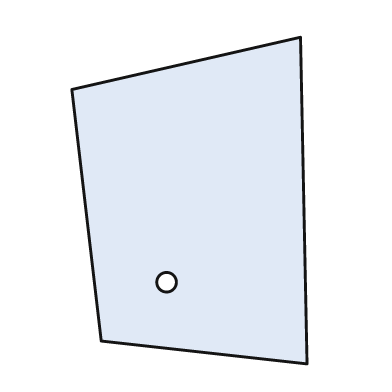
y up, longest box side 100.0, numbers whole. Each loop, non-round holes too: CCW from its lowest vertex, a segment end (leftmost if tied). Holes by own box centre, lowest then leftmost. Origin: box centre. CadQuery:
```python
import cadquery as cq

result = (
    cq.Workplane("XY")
    .moveTo(36.0, -50.0)
    .lineTo(34.0, 50.0)
    .lineTo(-36.0, 34.0)
    .lineTo(-27.0, -43.0)
    .close()
    .moveTo(-7.0, -25.0)
    .circle(3.0)
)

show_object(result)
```